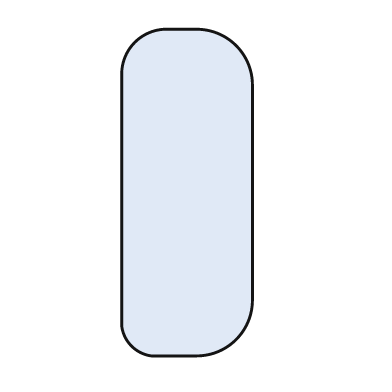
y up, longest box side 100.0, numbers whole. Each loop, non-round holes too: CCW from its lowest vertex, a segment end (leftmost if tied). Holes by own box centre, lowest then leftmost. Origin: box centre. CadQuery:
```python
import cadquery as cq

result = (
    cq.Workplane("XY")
    .moveTo(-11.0, -50.0)
    .lineTo(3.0, -50.0)
    .threePointArc((15.0, -45.0), (20.0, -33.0))
    .lineTo(20.0, 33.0)
    .threePointArc((15.0, 45.0), (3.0, 50.0))
    .lineTo(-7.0, 50.0)
    .threePointArc((-16.0, 46.0), (-20.0, 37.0))
    .lineTo(-20.0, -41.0)
    .threePointArc((-17.0, -47.0), (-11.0, -50.0))
    .close()
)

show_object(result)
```